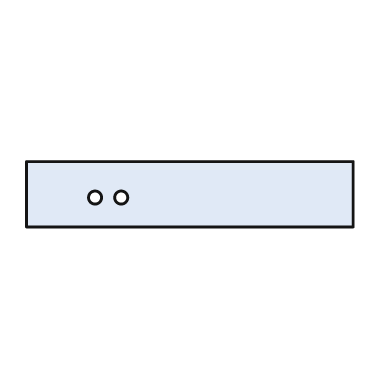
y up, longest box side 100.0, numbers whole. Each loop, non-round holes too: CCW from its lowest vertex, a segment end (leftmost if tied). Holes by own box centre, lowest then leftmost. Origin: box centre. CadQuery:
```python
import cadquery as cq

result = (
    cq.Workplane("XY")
    .moveTo(-50.0, -10.0)
    .lineTo(50.0, -10.0)
    .lineTo(50.0, 10.0)
    .lineTo(-50.0, 10.0)
    .close()
    .moveTo(-29.0, -1.0)
    .circle(2.0)
    .moveTo(-21.0, -1.0)
    .circle(2.0)
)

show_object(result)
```